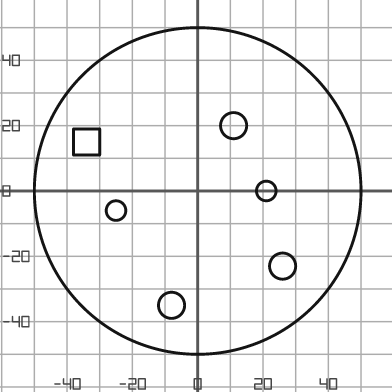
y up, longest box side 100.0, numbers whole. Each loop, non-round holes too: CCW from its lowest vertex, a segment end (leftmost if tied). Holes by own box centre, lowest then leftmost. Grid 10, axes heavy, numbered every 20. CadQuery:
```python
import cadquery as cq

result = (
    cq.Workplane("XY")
    .moveTo(0.0, 0.0)
    .circle(50.0)
    .moveTo(-8.0, -35.0)
    .circle(4.0)
    .moveTo(26.0, -23.0)
    .circle(4.0)
    .moveTo(-25.0, -6.0)
    .circle(3.0)
    .moveTo(21.0, 0.0)
    .circle(3.0)
    .moveTo(-38.0, 11.0)
    .lineTo(-30.0, 11.0)
    .lineTo(-30.0, 19.0)
    .lineTo(-38.0, 19.0)
    .close()
    .moveTo(11.0, 20.0)
    .circle(4.0)
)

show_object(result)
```